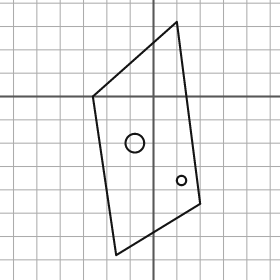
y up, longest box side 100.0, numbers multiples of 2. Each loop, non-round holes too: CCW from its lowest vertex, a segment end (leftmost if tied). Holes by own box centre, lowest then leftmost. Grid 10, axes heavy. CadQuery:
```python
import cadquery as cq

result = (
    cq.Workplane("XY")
    .moveTo(-16.0, -68.0)
    .lineTo(20.0, -46.0)
    .lineTo(10.0, 32.0)
    .lineTo(-26.0, 0.0)
    .close()
    .moveTo(12.0, -36.0)
    .circle(2.0)
    .moveTo(-8.0, -20.0)
    .circle(4.0)
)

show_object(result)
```